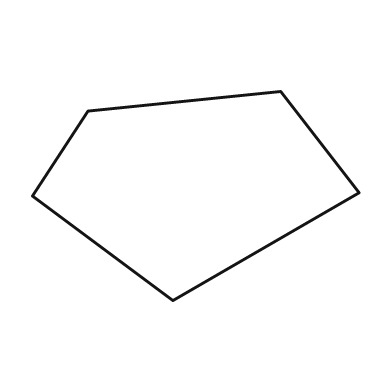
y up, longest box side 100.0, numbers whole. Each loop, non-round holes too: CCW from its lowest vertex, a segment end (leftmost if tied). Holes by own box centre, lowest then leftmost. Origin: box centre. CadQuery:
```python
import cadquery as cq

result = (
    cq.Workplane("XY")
    .moveTo(-7.0, -32.0)
    .lineTo(50.0, 1.0)
    .lineTo(26.0, 32.0)
    .lineTo(-33.0, 26.0)
    .lineTo(-50.0, 0.0)
    .close()
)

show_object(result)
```